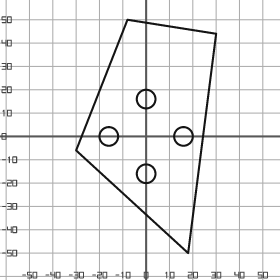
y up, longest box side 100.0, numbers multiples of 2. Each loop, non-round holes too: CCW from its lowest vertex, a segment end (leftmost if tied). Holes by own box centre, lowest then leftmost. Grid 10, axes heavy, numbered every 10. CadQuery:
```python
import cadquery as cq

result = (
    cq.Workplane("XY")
    .moveTo(18.0, -50.0)
    .lineTo(30.0, 44.0)
    .lineTo(-8.0, 50.0)
    .lineTo(-30.0, -6.0)
    .close()
    .moveTo(0.0, -16.0)
    .circle(4.0)
    .moveTo(-16.0, 0.0)
    .circle(4.0)
    .moveTo(16.0, 0.0)
    .circle(4.0)
    .moveTo(0.0, 16.0)
    .circle(4.0)
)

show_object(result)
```